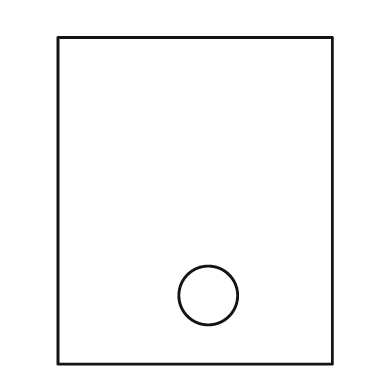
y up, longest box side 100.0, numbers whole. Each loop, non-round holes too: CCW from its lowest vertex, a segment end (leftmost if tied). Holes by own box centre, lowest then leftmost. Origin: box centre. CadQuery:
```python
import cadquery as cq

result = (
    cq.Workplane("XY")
    .moveTo(-42.0, -50.0)
    .lineTo(42.0, -50.0)
    .lineTo(42.0, 50.0)
    .lineTo(-42.0, 50.0)
    .close()
    .moveTo(4.0, -29.0)
    .circle(9.0)
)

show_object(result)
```